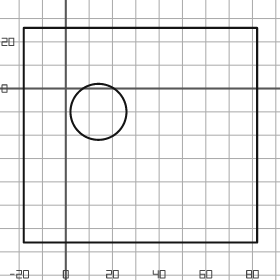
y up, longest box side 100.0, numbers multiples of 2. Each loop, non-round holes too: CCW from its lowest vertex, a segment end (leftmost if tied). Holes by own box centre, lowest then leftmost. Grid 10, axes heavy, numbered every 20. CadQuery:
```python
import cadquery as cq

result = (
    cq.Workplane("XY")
    .moveTo(-18.0, -66.0)
    .lineTo(82.0, -66.0)
    .lineTo(82.0, 26.0)
    .lineTo(-18.0, 26.0)
    .close()
    .moveTo(14.0, -10.0)
    .circle(12.0)
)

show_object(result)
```